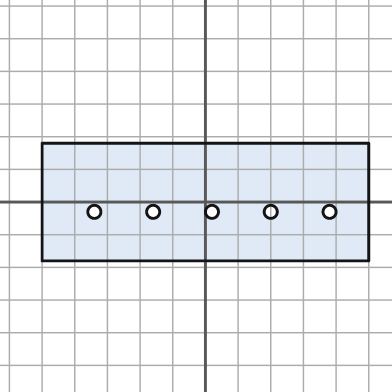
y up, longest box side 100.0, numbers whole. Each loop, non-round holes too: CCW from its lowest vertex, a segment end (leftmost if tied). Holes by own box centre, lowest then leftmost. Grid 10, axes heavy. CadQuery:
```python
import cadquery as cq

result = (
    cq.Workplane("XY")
    .moveTo(-50.0, -18.0)
    .lineTo(50.0, -18.0)
    .lineTo(50.0, 18.0)
    .lineTo(-50.0, 18.0)
    .close()
    .moveTo(-34.0, -3.0)
    .circle(2.0)
    .moveTo(-16.0, -3.0)
    .circle(2.0)
    .moveTo(2.0, -3.0)
    .circle(2.0)
    .moveTo(20.0, -3.0)
    .circle(2.0)
    .moveTo(38.0, -3.0)
    .circle(2.0)
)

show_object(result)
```